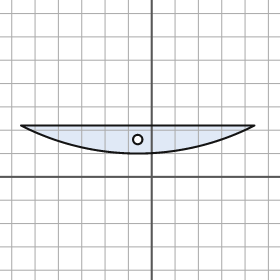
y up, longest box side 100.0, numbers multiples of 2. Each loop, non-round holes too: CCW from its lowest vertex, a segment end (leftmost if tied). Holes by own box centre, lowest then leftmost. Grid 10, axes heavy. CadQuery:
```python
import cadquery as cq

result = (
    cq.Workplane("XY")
    .moveTo(-56.0, 22.0)
    .threePointArc((-6.0, 10.0), (44.0, 22.0))
    .close()
    .moveTo(-6.0, 16.0)
    .circle(2.0)
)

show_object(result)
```